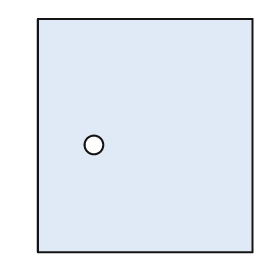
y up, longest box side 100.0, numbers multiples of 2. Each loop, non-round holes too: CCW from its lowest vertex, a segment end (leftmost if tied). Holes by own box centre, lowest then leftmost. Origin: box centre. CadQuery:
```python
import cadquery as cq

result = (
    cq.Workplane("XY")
    .moveTo(-46.0, -50.0)
    .lineTo(46.0, -50.0)
    .lineTo(46.0, 50.0)
    .lineTo(-46.0, 50.0)
    .close()
    .moveTo(-22.0, -4.0)
    .circle(4.0)
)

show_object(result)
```